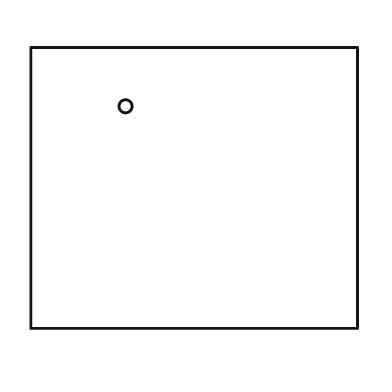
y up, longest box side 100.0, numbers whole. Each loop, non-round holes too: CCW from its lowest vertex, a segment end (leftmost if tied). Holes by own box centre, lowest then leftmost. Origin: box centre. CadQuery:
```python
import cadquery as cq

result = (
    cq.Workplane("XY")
    .moveTo(-50.0, -43.0)
    .lineTo(50.0, -43.0)
    .lineTo(50.0, 43.0)
    .lineTo(-50.0, 43.0)
    .close()
    .moveTo(-21.0, 25.0)
    .circle(2.0)
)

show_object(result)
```